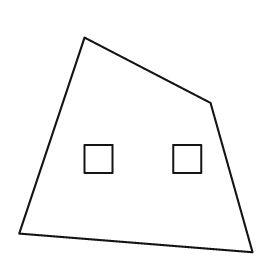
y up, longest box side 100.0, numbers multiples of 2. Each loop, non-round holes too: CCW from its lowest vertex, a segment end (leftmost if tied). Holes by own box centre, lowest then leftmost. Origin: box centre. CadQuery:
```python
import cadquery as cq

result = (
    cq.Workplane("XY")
    .moveTo(50.0, -46.0)
    .lineTo(32.0, 18.0)
    .lineTo(-22.0, 46.0)
    .lineTo(-50.0, -38.0)
    .close()
    .moveTo(-22.0, -12.0)
    .lineTo(-10.0, -12.0)
    .lineTo(-10.0, 0.0)
    .lineTo(-22.0, 0.0)
    .close()
    .moveTo(16.0, -12.0)
    .lineTo(28.0, -12.0)
    .lineTo(28.0, 0.0)
    .lineTo(16.0, 0.0)
    .close()
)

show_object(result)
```